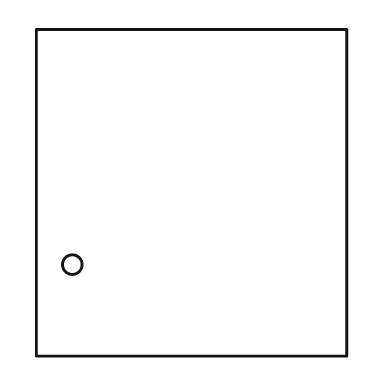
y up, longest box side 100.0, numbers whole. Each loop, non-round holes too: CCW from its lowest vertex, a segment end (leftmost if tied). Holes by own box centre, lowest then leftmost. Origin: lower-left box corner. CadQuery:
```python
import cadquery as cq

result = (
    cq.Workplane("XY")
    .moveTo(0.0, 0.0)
    .lineTo(95.0, 0.0)
    .lineTo(95.0, 100.0)
    .lineTo(0.0, 100.0)
    .close()
    .moveTo(11.0, 28.0)
    .circle(3.0)
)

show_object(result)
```